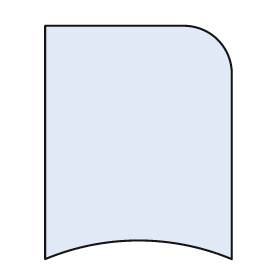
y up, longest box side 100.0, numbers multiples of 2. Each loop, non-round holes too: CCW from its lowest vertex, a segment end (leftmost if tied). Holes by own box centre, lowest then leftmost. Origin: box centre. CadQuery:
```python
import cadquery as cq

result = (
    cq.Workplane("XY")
    .moveTo(-40.0, -50.0)
    .threePointArc((0.0, -42.0), (40.0, -50.0))
    .lineTo(40.0, 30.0)
    .threePointArc((34.0, 44.0), (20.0, 50.0))
    .lineTo(-40.0, 50.0)
    .close()
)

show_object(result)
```